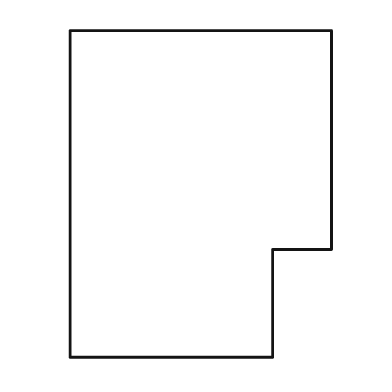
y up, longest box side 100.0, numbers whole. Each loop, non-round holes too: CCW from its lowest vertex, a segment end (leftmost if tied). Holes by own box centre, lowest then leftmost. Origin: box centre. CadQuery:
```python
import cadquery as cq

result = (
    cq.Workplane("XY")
    .moveTo(-40.0, -50.0)
    .lineTo(22.0, -50.0)
    .lineTo(22.0, -17.0)
    .lineTo(40.0, -17.0)
    .lineTo(40.0, 50.0)
    .lineTo(-40.0, 50.0)
    .close()
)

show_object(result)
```